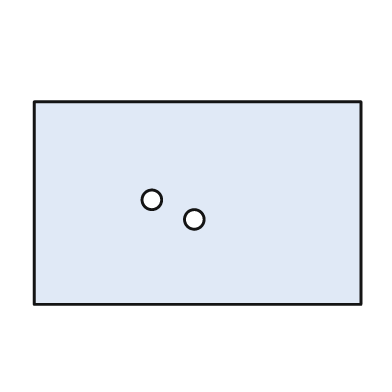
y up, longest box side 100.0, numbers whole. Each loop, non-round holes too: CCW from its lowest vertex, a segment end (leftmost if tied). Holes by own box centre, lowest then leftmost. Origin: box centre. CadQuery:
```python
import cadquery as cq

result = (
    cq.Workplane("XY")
    .moveTo(-50.0, -31.0)
    .lineTo(50.0, -31.0)
    .lineTo(50.0, 31.0)
    .lineTo(-50.0, 31.0)
    .close()
    .moveTo(-1.0, -5.0)
    .circle(3.0)
    .moveTo(-14.0, 1.0)
    .circle(3.0)
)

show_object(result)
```